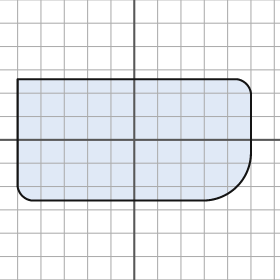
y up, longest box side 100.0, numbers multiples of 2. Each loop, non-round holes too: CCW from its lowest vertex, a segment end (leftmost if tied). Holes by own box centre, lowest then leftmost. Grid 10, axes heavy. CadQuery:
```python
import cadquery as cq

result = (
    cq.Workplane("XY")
    .moveTo(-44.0, -26.0)
    .lineTo(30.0, -26.0)
    .threePointArc((44.0, -20.0), (50.0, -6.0))
    .lineTo(50.0, 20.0)
    .threePointArc((48.0, 24.0), (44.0, 26.0))
    .lineTo(-50.0, 26.0)
    .lineTo(-50.0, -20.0)
    .threePointArc((-48.0, -24.0), (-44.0, -26.0))
    .close()
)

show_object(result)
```